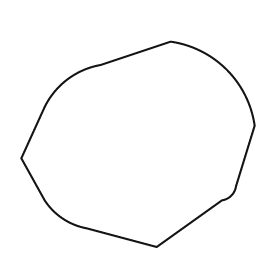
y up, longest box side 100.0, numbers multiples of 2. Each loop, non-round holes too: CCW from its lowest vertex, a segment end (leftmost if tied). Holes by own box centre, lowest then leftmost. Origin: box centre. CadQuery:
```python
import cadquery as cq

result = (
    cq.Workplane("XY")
    .moveTo(8.0, -44.0)
    .lineTo(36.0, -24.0)
    .threePointArc((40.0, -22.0), (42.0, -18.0))
    .lineTo(50.0, 8.0)
    .threePointArc((38.0, 32.0), (14.0, 44.0))
    .lineTo(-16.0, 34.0)
    .threePointArc((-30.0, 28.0), (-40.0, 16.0))
    .lineTo(-50.0, -6.0)
    .lineTo(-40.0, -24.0)
    .threePointArc((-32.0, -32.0), (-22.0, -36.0))
    .close()
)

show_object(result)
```